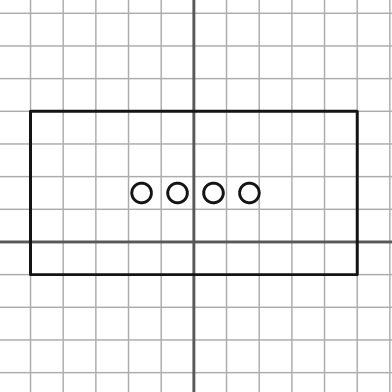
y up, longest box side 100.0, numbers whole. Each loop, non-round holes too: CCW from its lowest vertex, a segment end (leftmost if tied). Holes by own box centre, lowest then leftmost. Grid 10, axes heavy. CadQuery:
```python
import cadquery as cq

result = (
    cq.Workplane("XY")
    .moveTo(-50.0, -10.0)
    .lineTo(50.0, -10.0)
    .lineTo(50.0, 40.0)
    .lineTo(-50.0, 40.0)
    .close()
    .moveTo(-16.0, 15.0)
    .circle(3.0)
    .moveTo(-5.0, 15.0)
    .circle(3.0)
    .moveTo(6.0, 15.0)
    .circle(3.0)
    .moveTo(17.0, 15.0)
    .circle(3.0)
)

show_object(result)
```